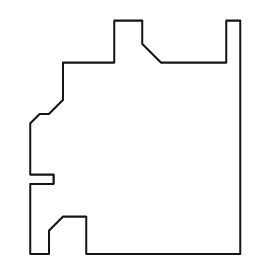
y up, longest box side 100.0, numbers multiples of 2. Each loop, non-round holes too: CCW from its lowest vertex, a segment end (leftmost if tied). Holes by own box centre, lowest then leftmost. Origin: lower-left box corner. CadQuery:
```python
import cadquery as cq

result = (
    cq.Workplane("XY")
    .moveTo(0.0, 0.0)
    .lineTo(8.0, 0.0)
    .lineTo(8.0, 10.0)
    .lineTo(14.0, 16.0)
    .lineTo(24.0, 16.0)
    .lineTo(24.0, 0.0)
    .lineTo(90.0, 0.0)
    .lineTo(90.0, 100.0)
    .lineTo(84.0, 100.0)
    .lineTo(84.0, 82.0)
    .lineTo(56.0, 82.0)
    .lineTo(48.0, 90.0)
    .lineTo(48.0, 100.0)
    .lineTo(36.0, 100.0)
    .lineTo(36.0, 82.0)
    .lineTo(14.0, 82.0)
    .lineTo(14.0, 66.0)
    .lineTo(8.0, 60.0)
    .lineTo(4.0, 60.0)
    .lineTo(0.0, 56.0)
    .lineTo(0.0, 34.0)
    .lineTo(10.0, 34.0)
    .lineTo(10.0, 30.0)
    .lineTo(0.0, 30.0)
    .close()
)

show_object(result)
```